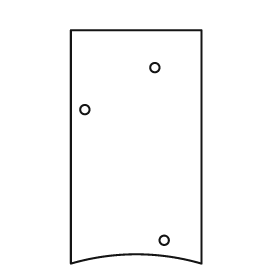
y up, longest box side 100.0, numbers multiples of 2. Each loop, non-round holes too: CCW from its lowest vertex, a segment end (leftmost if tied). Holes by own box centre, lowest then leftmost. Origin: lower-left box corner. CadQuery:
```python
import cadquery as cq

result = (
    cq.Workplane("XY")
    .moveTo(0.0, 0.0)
    .threePointArc((28.0, 4.0), (56.0, 0.0))
    .lineTo(56.0, 100.0)
    .lineTo(0.0, 100.0)
    .close()
    .moveTo(40.0, 10.0)
    .circle(2.0)
    .moveTo(6.0, 66.0)
    .circle(2.0)
    .moveTo(36.0, 84.0)
    .circle(2.0)
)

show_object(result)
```